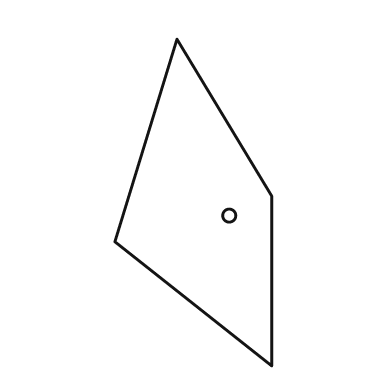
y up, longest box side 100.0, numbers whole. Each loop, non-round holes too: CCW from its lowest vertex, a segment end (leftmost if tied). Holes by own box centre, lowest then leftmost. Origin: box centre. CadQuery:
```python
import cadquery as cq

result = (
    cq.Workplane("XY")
    .moveTo(24.0, -50.0)
    .lineTo(24.0, 2.0)
    .lineTo(-5.0, 50.0)
    .lineTo(-24.0, -12.0)
    .close()
    .moveTo(11.0, -4.0)
    .circle(2.0)
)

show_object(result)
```